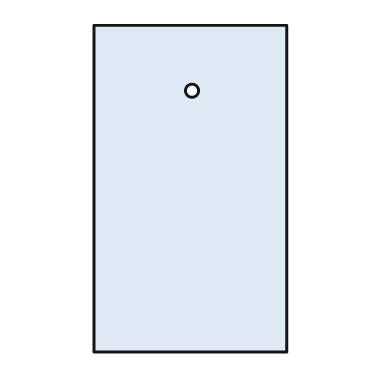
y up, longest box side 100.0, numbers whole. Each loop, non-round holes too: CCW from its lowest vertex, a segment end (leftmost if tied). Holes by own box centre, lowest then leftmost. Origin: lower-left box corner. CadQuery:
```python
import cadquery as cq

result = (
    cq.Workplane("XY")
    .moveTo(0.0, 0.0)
    .lineTo(59.0, 0.0)
    .lineTo(59.0, 100.0)
    .lineTo(0.0, 100.0)
    .close()
    .moveTo(30.0, 80.0)
    .circle(2.0)
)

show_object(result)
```